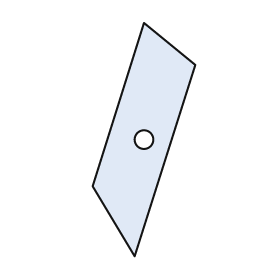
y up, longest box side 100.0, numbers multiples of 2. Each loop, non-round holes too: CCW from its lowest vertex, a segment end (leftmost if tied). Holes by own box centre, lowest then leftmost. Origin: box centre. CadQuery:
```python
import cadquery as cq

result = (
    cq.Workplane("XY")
    .moveTo(-4.0, -50.0)
    .lineTo(22.0, 32.0)
    .lineTo(0.0, 50.0)
    .lineTo(-22.0, -20.0)
    .close()
    .moveTo(0.0, 0.0)
    .circle(4.0)
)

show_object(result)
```